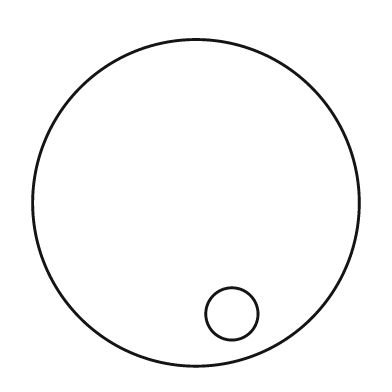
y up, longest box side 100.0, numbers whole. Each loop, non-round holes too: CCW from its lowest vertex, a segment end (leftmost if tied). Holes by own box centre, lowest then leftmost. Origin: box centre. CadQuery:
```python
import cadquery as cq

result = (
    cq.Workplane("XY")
    .moveTo(0.0, 0.0)
    .circle(50.0)
    .moveTo(11.0, -34.0)
    .circle(8.0)
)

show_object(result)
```